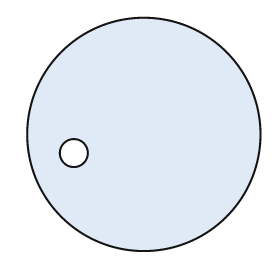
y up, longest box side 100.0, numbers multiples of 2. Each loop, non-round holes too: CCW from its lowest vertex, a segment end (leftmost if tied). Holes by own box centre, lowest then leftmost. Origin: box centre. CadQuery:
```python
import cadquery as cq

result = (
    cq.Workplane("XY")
    .moveTo(0.0, 0.0)
    .circle(50.0)
    .moveTo(-30.0, -8.0)
    .circle(6.0)
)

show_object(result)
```